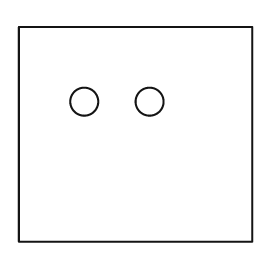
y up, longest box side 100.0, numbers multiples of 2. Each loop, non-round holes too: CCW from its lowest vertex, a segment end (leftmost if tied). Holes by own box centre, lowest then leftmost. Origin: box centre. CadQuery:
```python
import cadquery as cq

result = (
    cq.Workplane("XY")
    .moveTo(-50.0, -46.0)
    .lineTo(50.0, -46.0)
    .lineTo(50.0, 46.0)
    .lineTo(-50.0, 46.0)
    .close()
    .moveTo(-22.0, 14.0)
    .circle(6.0)
    .moveTo(6.0, 14.0)
    .circle(6.0)
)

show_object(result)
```